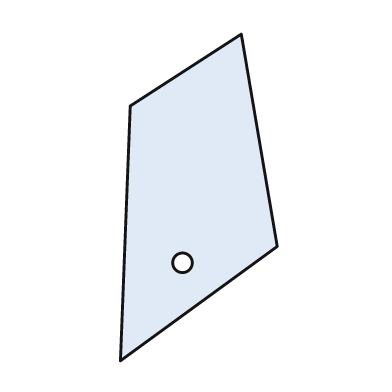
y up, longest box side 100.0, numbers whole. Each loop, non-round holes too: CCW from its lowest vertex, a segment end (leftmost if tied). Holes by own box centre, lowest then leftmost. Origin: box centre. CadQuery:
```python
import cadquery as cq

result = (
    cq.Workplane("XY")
    .moveTo(-24.0, -50.0)
    .lineTo(24.0, -15.0)
    .lineTo(13.0, 50.0)
    .lineTo(-21.0, 28.0)
    .close()
    .moveTo(-5.0, -20.0)
    .circle(3.0)
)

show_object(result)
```